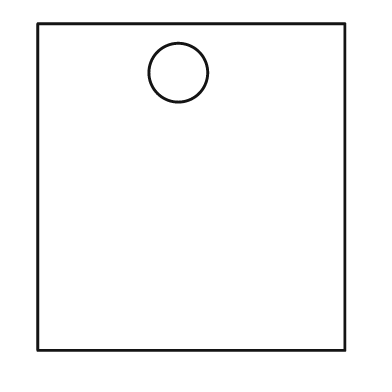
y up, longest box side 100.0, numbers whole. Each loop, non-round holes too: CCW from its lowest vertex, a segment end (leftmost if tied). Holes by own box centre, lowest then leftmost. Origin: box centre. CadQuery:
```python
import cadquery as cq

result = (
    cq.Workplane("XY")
    .moveTo(-47.0, -50.0)
    .lineTo(47.0, -50.0)
    .lineTo(47.0, 50.0)
    .lineTo(-47.0, 50.0)
    .close()
    .moveTo(-4.0, 35.0)
    .circle(9.0)
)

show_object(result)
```